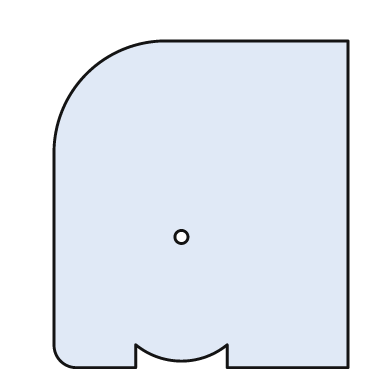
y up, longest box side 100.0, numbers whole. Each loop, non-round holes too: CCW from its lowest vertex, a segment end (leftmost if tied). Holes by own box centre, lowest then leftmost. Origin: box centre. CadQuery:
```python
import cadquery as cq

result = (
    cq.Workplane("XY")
    .moveTo(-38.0, -50.0)
    .lineTo(-20.0, -50.0)
    .lineTo(-20.0, -43.0)
    .threePointArc((-6.0, -48.0), (8.0, -43.0))
    .lineTo(8.0, -50.0)
    .lineTo(45.0, -50.0)
    .lineTo(45.0, 50.0)
    .lineTo(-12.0, 50.0)
    .threePointArc((-35.0, 40.0), (-45.0, 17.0))
    .lineTo(-45.0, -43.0)
    .threePointArc((-43.0, -48.0), (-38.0, -50.0))
    .close()
    .moveTo(-6.0, -10.0)
    .circle(2.0)
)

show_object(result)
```